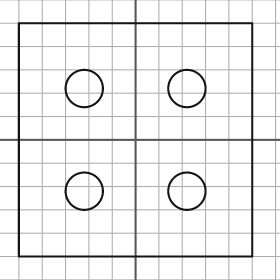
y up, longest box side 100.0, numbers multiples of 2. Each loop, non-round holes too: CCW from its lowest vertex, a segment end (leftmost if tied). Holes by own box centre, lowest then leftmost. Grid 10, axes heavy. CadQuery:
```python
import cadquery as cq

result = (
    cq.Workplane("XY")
    .moveTo(-50.0, -50.0)
    .lineTo(50.0, -50.0)
    .lineTo(50.0, 50.0)
    .lineTo(-50.0, 50.0)
    .close()
    .moveTo(-22.0, -22.0)
    .circle(8.0)
    .moveTo(22.0, -22.0)
    .circle(8.0)
    .moveTo(-22.0, 22.0)
    .circle(8.0)
    .moveTo(22.0, 22.0)
    .circle(8.0)
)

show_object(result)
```